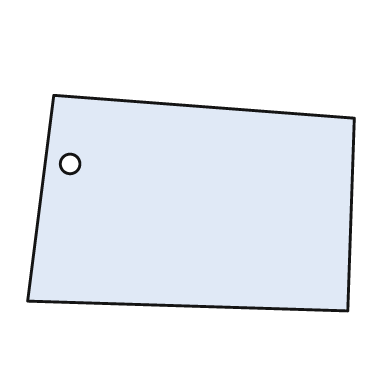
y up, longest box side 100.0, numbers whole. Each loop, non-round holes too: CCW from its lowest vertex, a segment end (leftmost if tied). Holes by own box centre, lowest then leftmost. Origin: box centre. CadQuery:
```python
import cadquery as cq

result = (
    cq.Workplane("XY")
    .moveTo(48.0, -33.0)
    .lineTo(50.0, 26.0)
    .lineTo(-42.0, 33.0)
    .lineTo(-50.0, -30.0)
    .close()
    .moveTo(-37.0, 12.0)
    .circle(3.0)
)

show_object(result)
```